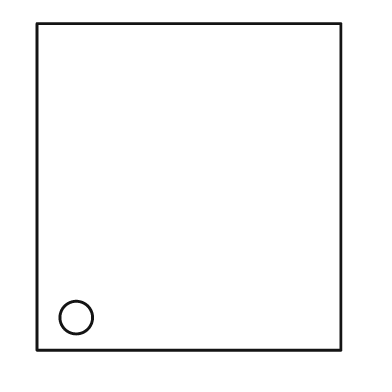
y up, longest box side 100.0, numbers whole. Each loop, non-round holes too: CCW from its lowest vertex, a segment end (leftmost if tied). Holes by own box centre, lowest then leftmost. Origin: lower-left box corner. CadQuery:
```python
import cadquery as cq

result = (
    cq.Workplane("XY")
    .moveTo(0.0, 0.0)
    .lineTo(93.0, 0.0)
    .lineTo(93.0, 100.0)
    .lineTo(0.0, 100.0)
    .close()
    .moveTo(12.0, 10.0)
    .circle(5.0)
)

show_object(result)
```